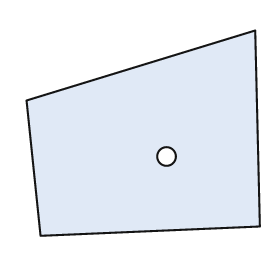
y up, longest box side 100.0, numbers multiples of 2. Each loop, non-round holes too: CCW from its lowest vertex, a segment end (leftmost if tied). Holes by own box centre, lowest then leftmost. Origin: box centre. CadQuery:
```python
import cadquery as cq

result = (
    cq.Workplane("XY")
    .moveTo(-44.0, -44.0)
    .lineTo(50.0, -40.0)
    .lineTo(48.0, 44.0)
    .lineTo(-50.0, 14.0)
    .close()
    .moveTo(10.0, -10.0)
    .circle(4.0)
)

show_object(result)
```